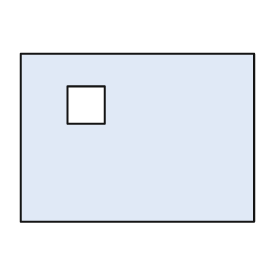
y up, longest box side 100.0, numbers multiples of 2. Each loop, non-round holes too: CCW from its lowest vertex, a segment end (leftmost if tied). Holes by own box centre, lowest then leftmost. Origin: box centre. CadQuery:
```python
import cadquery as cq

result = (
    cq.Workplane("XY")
    .moveTo(-50.0, -36.0)
    .lineTo(50.0, -36.0)
    .lineTo(50.0, 36.0)
    .lineTo(-50.0, 36.0)
    .close()
    .moveTo(-30.0, 6.0)
    .lineTo(-14.0, 6.0)
    .lineTo(-14.0, 22.0)
    .lineTo(-30.0, 22.0)
    .close()
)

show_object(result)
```